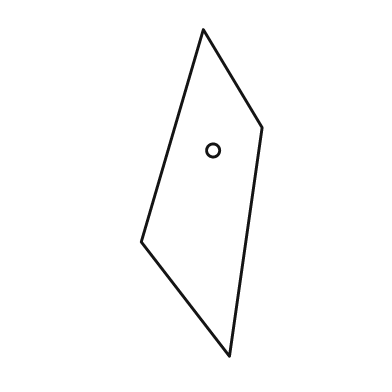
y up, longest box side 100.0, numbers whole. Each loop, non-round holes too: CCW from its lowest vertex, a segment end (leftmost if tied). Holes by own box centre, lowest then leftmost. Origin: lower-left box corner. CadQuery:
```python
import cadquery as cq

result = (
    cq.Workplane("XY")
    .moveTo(27.0, 0.0)
    .lineTo(37.0, 70.0)
    .lineTo(19.0, 100.0)
    .lineTo(0.0, 35.0)
    .close()
    .moveTo(22.0, 63.0)
    .circle(2.0)
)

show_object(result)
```